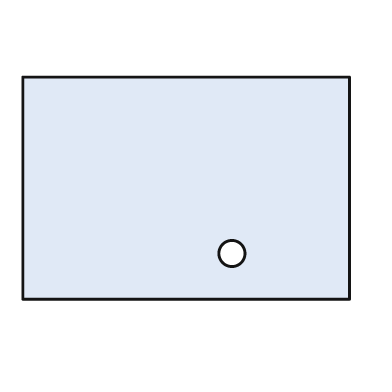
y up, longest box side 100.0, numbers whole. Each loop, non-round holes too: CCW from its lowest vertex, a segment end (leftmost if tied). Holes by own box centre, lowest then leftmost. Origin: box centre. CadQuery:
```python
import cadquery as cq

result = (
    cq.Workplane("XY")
    .moveTo(-50.0, -34.0)
    .lineTo(50.0, -34.0)
    .lineTo(50.0, 34.0)
    .lineTo(-50.0, 34.0)
    .close()
    .moveTo(14.0, -20.0)
    .circle(4.0)
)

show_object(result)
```